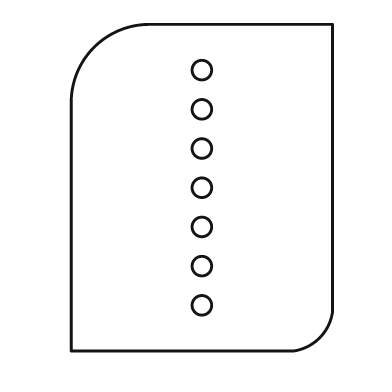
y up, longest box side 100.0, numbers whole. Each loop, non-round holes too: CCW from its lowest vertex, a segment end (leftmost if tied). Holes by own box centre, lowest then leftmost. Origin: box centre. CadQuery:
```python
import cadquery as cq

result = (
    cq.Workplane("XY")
    .moveTo(-40.0, -50.0)
    .lineTo(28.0, -50.0)
    .threePointArc((36.0, -46.0), (40.0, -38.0))
    .lineTo(40.0, 50.0)
    .lineTo(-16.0, 50.0)
    .threePointArc((-33.0, 43.0), (-40.0, 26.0))
    .close()
    .moveTo(0.0, -36.0)
    .circle(3.0)
    .moveTo(0.0, -24.0)
    .circle(3.0)
    .moveTo(0.0, -12.0)
    .circle(3.0)
    .moveTo(0.0, 0.0)
    .circle(3.0)
    .moveTo(0.0, 12.0)
    .circle(3.0)
    .moveTo(0.0, 24.0)
    .circle(3.0)
    .moveTo(0.0, 36.0)
    .circle(3.0)
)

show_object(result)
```